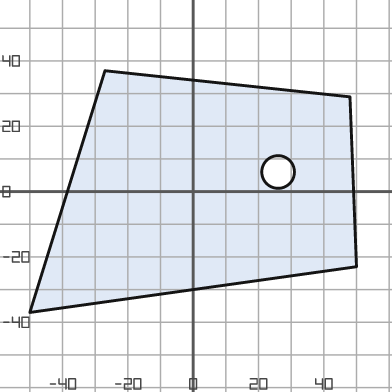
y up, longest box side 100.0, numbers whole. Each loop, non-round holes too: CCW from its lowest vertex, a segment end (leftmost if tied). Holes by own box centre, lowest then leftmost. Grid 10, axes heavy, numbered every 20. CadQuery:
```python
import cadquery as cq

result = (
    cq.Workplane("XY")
    .moveTo(-50.0, -37.0)
    .lineTo(50.0, -23.0)
    .lineTo(48.0, 29.0)
    .lineTo(-27.0, 37.0)
    .close()
    .moveTo(26.0, 6.0)
    .circle(5.0)
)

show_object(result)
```